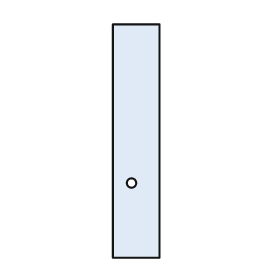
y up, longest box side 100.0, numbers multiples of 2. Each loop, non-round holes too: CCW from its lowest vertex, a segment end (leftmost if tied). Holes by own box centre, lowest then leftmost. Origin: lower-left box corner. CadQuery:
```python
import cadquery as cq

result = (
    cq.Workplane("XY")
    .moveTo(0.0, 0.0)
    .lineTo(20.0, 0.0)
    .lineTo(20.0, 100.0)
    .lineTo(0.0, 100.0)
    .close()
    .moveTo(8.0, 32.0)
    .circle(2.0)
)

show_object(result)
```